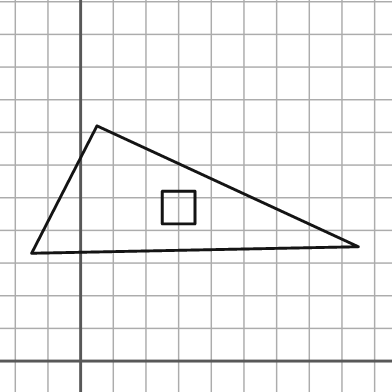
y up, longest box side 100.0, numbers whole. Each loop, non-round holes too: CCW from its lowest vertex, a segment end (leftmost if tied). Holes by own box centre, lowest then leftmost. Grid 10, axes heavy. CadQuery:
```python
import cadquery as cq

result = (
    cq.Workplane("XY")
    .moveTo(-15.0, 33.0)
    .lineTo(85.0, 35.0)
    .lineTo(5.0, 72.0)
    .close()
    .moveTo(25.0, 42.0)
    .lineTo(35.0, 42.0)
    .lineTo(35.0, 52.0)
    .lineTo(25.0, 52.0)
    .close()
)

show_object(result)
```